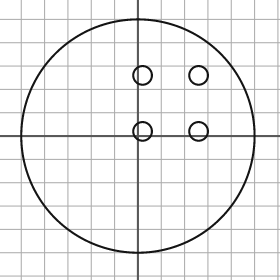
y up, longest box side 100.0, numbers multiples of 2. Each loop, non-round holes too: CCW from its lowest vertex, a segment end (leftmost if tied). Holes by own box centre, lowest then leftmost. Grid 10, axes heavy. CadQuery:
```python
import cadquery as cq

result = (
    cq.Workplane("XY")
    .moveTo(0.0, 0.0)
    .circle(50.0)
    .moveTo(2.0, 2.0)
    .circle(4.0)
    .moveTo(26.0, 2.0)
    .circle(4.0)
    .moveTo(2.0, 26.0)
    .circle(4.0)
    .moveTo(26.0, 26.0)
    .circle(4.0)
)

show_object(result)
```